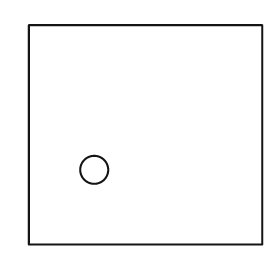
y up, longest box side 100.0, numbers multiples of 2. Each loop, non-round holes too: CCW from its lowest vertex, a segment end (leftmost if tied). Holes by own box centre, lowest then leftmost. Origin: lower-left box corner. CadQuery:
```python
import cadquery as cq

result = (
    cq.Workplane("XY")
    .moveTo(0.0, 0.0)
    .lineTo(100.0, 0.0)
    .lineTo(100.0, 94.0)
    .lineTo(0.0, 94.0)
    .close()
    .moveTo(28.0, 32.0)
    .circle(6.0)
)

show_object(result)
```